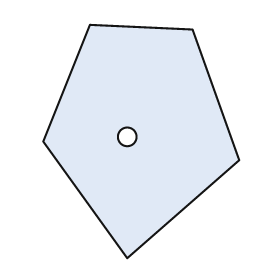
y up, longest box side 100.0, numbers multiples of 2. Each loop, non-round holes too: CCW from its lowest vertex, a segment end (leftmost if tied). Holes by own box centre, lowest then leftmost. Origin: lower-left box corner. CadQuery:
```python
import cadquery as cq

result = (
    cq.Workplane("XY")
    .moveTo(36.0, 0.0)
    .lineTo(84.0, 42.0)
    .lineTo(64.0, 98.0)
    .lineTo(20.0, 100.0)
    .lineTo(0.0, 50.0)
    .close()
    .moveTo(36.0, 52.0)
    .circle(4.0)
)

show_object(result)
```